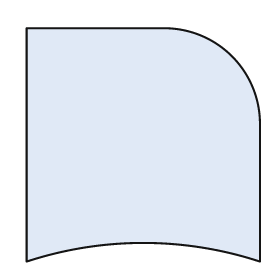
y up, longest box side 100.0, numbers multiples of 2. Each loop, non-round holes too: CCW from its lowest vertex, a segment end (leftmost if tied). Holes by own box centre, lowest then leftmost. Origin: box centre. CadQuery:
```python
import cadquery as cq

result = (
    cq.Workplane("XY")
    .moveTo(-50.0, -50.0)
    .threePointArc((0.0, -42.0), (50.0, -50.0))
    .lineTo(50.0, 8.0)
    .threePointArc((38.0, 38.0), (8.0, 50.0))
    .lineTo(-50.0, 50.0)
    .close()
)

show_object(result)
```